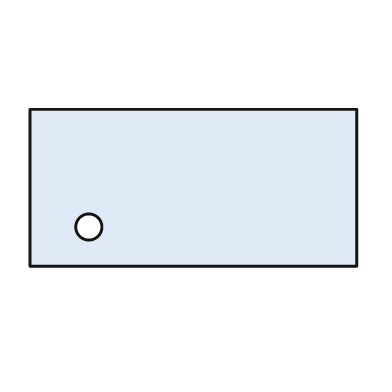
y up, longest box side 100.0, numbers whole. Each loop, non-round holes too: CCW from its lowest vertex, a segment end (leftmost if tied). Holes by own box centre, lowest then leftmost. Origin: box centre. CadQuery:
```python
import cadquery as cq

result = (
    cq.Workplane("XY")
    .moveTo(-50.0, -24.0)
    .lineTo(50.0, -24.0)
    .lineTo(50.0, 24.0)
    .lineTo(-50.0, 24.0)
    .close()
    .moveTo(-32.0, -12.0)
    .circle(4.0)
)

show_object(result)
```